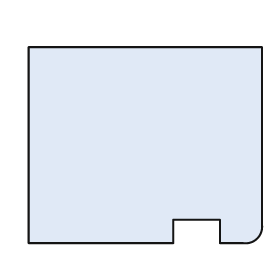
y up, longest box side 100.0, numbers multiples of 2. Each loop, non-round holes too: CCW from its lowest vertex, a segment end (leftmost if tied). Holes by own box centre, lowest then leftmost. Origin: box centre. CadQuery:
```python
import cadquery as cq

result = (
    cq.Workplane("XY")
    .moveTo(-50.0, -42.0)
    .lineTo(12.0, -42.0)
    .lineTo(12.0, -32.0)
    .lineTo(32.0, -32.0)
    .lineTo(32.0, -42.0)
    .lineTo(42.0, -42.0)
    .threePointArc((48.0, -40.0), (50.0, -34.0))
    .lineTo(50.0, 42.0)
    .lineTo(-50.0, 42.0)
    .close()
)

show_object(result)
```